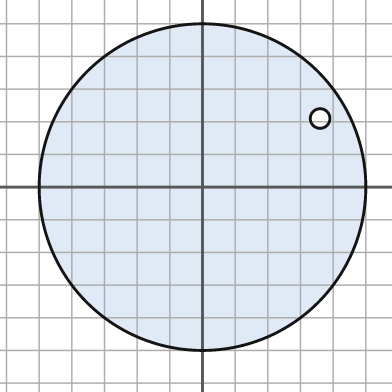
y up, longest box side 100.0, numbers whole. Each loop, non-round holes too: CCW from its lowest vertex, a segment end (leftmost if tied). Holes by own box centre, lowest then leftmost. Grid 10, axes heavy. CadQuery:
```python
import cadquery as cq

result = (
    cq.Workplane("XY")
    .moveTo(0.0, 0.0)
    .circle(50.0)
    .moveTo(36.0, 21.0)
    .circle(3.0)
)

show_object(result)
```